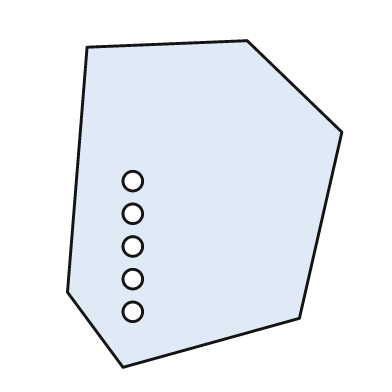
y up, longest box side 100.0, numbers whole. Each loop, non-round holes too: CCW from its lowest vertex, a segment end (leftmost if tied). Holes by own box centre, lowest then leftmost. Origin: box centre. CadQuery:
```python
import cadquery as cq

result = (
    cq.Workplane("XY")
    .moveTo(-25.0, -50.0)
    .lineTo(29.0, -35.0)
    .lineTo(42.0, 22.0)
    .lineTo(13.0, 50.0)
    .lineTo(-36.0, 48.0)
    .lineTo(-42.0, -27.0)
    .close()
    .moveTo(-22.0, -33.0)
    .circle(3.0)
    .moveTo(-22.0, -23.0)
    .circle(3.0)
    .moveTo(-22.0, -13.0)
    .circle(3.0)
    .moveTo(-22.0, -3.0)
    .circle(3.0)
    .moveTo(-22.0, 7.0)
    .circle(3.0)
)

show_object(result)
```